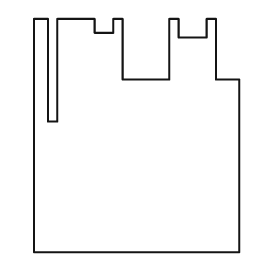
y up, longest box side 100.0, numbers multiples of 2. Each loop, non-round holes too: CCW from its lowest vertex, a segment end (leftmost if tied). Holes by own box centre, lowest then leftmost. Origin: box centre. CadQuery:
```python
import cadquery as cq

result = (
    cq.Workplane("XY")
    .moveTo(-44.0, -50.0)
    .lineTo(44.0, -50.0)
    .lineTo(44.0, 24.0)
    .lineTo(34.0, 24.0)
    .lineTo(34.0, 50.0)
    .lineTo(30.0, 50.0)
    .lineTo(30.0, 42.0)
    .lineTo(18.0, 42.0)
    .lineTo(18.0, 50.0)
    .lineTo(14.0, 50.0)
    .lineTo(14.0, 24.0)
    .lineTo(-6.0, 24.0)
    .lineTo(-6.0, 50.0)
    .lineTo(-10.0, 50.0)
    .lineTo(-10.0, 44.0)
    .lineTo(-18.0, 44.0)
    .lineTo(-18.0, 50.0)
    .lineTo(-34.0, 50.0)
    .lineTo(-34.0, 6.0)
    .lineTo(-38.0, 6.0)
    .lineTo(-38.0, 50.0)
    .lineTo(-44.0, 50.0)
    .close()
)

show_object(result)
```